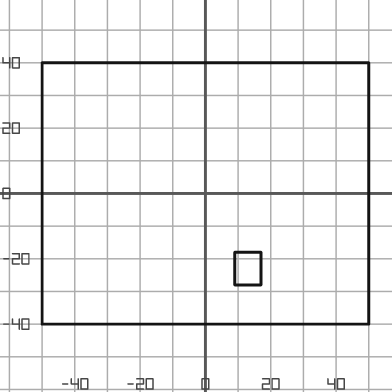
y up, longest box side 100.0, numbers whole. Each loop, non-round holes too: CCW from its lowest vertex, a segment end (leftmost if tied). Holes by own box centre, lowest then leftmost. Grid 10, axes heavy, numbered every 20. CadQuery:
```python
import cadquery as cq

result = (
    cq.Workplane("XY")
    .moveTo(-50.0, -40.0)
    .lineTo(50.0, -40.0)
    .lineTo(50.0, 40.0)
    .lineTo(-50.0, 40.0)
    .close()
    .moveTo(9.0, -28.0)
    .lineTo(17.0, -28.0)
    .lineTo(17.0, -18.0)
    .lineTo(9.0, -18.0)
    .close()
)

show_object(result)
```